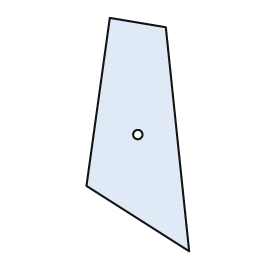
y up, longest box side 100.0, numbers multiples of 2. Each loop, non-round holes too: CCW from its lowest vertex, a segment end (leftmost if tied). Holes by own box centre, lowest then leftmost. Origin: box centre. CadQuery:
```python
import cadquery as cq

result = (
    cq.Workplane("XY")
    .moveTo(22.0, -50.0)
    .lineTo(12.0, 46.0)
    .lineTo(-12.0, 50.0)
    .lineTo(-22.0, -22.0)
    .close()
    .moveTo(0.0, 0.0)
    .circle(2.0)
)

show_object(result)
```